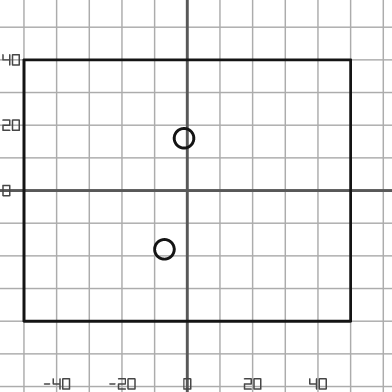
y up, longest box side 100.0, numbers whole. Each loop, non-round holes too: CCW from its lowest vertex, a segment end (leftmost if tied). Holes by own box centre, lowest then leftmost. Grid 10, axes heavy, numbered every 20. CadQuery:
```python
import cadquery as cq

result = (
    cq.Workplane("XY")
    .moveTo(-50.0, -40.0)
    .lineTo(50.0, -40.0)
    .lineTo(50.0, 40.0)
    .lineTo(-50.0, 40.0)
    .close()
    .moveTo(-7.0, -18.0)
    .circle(3.0)
    .moveTo(-1.0, 16.0)
    .circle(3.0)
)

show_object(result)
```